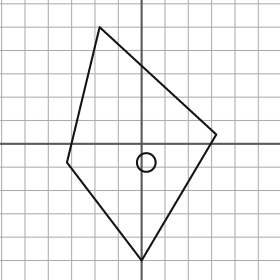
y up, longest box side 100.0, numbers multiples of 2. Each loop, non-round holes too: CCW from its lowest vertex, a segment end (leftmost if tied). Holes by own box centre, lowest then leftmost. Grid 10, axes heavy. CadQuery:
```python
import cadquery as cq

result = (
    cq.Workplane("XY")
    .moveTo(0.0, -50.0)
    .lineTo(32.0, 4.0)
    .lineTo(-18.0, 50.0)
    .lineTo(-32.0, -8.0)
    .close()
    .moveTo(2.0, -8.0)
    .circle(4.0)
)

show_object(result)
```